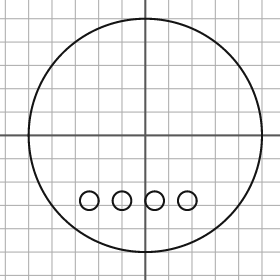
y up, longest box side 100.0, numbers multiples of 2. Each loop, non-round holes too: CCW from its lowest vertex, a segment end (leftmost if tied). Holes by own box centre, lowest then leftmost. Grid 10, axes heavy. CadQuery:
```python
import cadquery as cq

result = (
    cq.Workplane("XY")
    .moveTo(0.0, 0.0)
    .circle(50.0)
    .moveTo(-24.0, -28.0)
    .circle(4.0)
    .moveTo(-10.0, -28.0)
    .circle(4.0)
    .moveTo(4.0, -28.0)
    .circle(4.0)
    .moveTo(18.0, -28.0)
    .circle(4.0)
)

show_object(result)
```